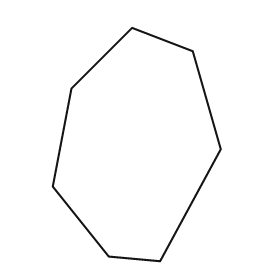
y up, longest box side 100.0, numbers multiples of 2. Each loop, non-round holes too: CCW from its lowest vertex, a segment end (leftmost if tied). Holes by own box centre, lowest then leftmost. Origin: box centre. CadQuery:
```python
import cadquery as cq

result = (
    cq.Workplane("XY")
    .moveTo(10.0, -50.0)
    .lineTo(36.0, -2.0)
    .lineTo(24.0, 40.0)
    .lineTo(-2.0, 50.0)
    .lineTo(-28.0, 24.0)
    .lineTo(-36.0, -18.0)
    .lineTo(-12.0, -48.0)
    .close()
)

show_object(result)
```